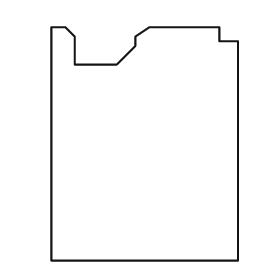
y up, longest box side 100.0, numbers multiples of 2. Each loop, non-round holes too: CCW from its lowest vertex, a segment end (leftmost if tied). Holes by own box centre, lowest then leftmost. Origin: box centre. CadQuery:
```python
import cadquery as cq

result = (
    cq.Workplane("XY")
    .moveTo(-40.0, -50.0)
    .lineTo(40.0, -50.0)
    .lineTo(40.0, 44.0)
    .lineTo(32.0, 44.0)
    .lineTo(32.0, 50.0)
    .lineTo(2.0, 50.0)
    .lineTo(-4.0, 46.0)
    .lineTo(-4.0, 42.0)
    .lineTo(-12.0, 34.0)
    .lineTo(-30.0, 34.0)
    .lineTo(-30.0, 46.0)
    .lineTo(-34.0, 50.0)
    .lineTo(-40.0, 50.0)
    .close()
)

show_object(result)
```